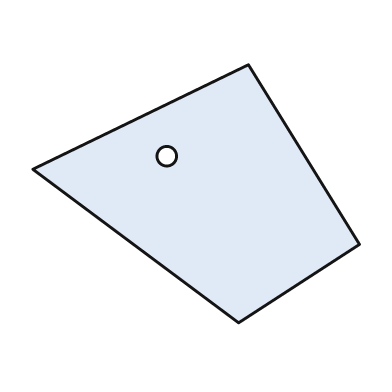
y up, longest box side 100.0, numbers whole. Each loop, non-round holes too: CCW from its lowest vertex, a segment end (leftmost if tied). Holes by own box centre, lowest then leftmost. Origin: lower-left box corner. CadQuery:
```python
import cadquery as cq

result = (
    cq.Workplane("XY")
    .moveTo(63.0, 0.0)
    .lineTo(100.0, 24.0)
    .lineTo(66.0, 79.0)
    .lineTo(0.0, 47.0)
    .close()
    .moveTo(41.0, 51.0)
    .circle(3.0)
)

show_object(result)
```